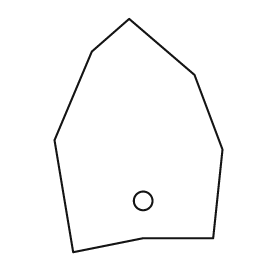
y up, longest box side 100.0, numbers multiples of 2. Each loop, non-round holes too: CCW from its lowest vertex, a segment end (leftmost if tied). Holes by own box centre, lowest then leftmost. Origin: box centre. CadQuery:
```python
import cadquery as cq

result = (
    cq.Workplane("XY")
    .moveTo(-28.0, -50.0)
    .lineTo(2.0, -44.0)
    .lineTo(32.0, -44.0)
    .lineTo(36.0, -6.0)
    .lineTo(24.0, 26.0)
    .lineTo(-4.0, 50.0)
    .lineTo(-20.0, 36.0)
    .lineTo(-36.0, -2.0)
    .close()
    .moveTo(2.0, -28.0)
    .circle(4.0)
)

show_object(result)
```